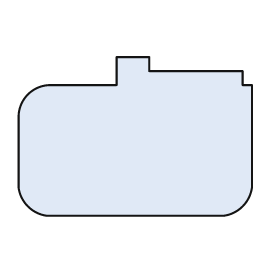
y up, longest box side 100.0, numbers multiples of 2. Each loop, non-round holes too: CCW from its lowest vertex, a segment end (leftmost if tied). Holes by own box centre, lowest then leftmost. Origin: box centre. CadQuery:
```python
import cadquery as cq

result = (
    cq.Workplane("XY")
    .moveTo(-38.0, -34.0)
    .lineTo(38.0, -34.0)
    .threePointArc((46.0, -30.0), (50.0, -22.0))
    .lineTo(50.0, 22.0)
    .lineTo(46.0, 22.0)
    .lineTo(46.0, 28.0)
    .lineTo(6.0, 28.0)
    .lineTo(6.0, 34.0)
    .lineTo(-8.0, 34.0)
    .lineTo(-8.0, 22.0)
    .lineTo(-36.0, 22.0)
    .threePointArc((-46.0, 18.0), (-50.0, 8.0))
    .lineTo(-50.0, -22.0)
    .threePointArc((-46.0, -30.0), (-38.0, -34.0))
    .close()
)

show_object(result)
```